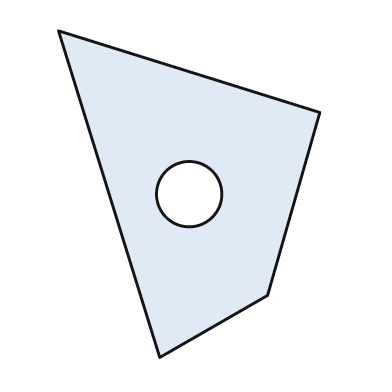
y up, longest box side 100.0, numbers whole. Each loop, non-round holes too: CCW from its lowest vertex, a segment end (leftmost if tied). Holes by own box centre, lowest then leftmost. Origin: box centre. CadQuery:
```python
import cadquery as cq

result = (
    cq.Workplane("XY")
    .moveTo(-9.0, -50.0)
    .lineTo(24.0, -31.0)
    .lineTo(40.0, 25.0)
    .lineTo(-40.0, 50.0)
    .close()
    .moveTo(0.0, 0.0)
    .circle(10.0)
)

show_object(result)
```